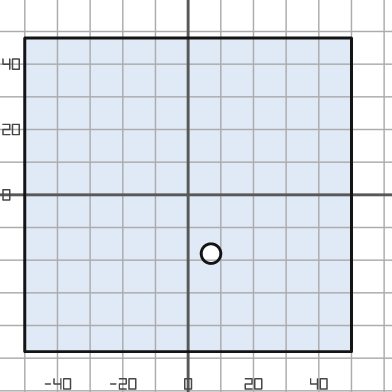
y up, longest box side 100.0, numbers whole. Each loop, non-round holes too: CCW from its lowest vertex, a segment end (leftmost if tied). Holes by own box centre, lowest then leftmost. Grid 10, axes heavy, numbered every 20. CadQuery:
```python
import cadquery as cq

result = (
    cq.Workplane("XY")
    .moveTo(-50.0, -48.0)
    .lineTo(50.0, -48.0)
    .lineTo(50.0, 48.0)
    .lineTo(-50.0, 48.0)
    .close()
    .moveTo(7.0, -18.0)
    .circle(3.0)
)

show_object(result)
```